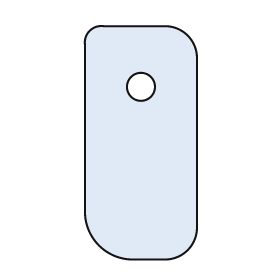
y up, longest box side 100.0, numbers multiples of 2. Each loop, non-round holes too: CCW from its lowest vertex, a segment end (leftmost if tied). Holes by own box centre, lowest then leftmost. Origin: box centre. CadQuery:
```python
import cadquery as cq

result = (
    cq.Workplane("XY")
    .moveTo(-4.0, -50.0)
    .lineTo(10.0, -50.0)
    .threePointArc((20.0, -46.0), (24.0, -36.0))
    .lineTo(24.0, 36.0)
    .threePointArc((20.0, 46.0), (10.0, 50.0))
    .lineTo(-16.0, 50.0)
    .threePointArc((-22.0, 48.0), (-24.0, 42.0))
    .lineTo(-24.0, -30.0)
    .threePointArc((-18.0, -44.0), (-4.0, -50.0))
    .close()
    .moveTo(0.0, 24.0)
    .circle(6.0)
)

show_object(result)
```